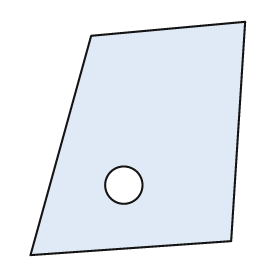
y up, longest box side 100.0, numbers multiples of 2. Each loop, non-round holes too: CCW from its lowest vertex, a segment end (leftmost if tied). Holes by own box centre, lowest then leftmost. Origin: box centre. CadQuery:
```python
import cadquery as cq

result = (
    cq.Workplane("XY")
    .moveTo(-46.0, -50.0)
    .lineTo(40.0, -44.0)
    .lineTo(46.0, 50.0)
    .lineTo(-20.0, 44.0)
    .close()
    .moveTo(-6.0, -20.0)
    .circle(8.0)
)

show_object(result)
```